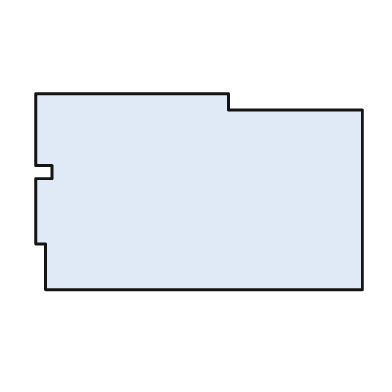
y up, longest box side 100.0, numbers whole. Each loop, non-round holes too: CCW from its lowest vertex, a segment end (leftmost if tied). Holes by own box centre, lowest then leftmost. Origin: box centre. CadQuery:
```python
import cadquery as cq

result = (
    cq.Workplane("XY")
    .moveTo(-47.0, -30.0)
    .lineTo(50.0, -30.0)
    .lineTo(50.0, 25.0)
    .lineTo(9.0, 25.0)
    .lineTo(9.0, 30.0)
    .lineTo(-50.0, 30.0)
    .lineTo(-50.0, 8.0)
    .lineTo(-45.0, 8.0)
    .lineTo(-45.0, 4.0)
    .lineTo(-50.0, 4.0)
    .lineTo(-50.0, -16.0)
    .lineTo(-47.0, -16.0)
    .close()
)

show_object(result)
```